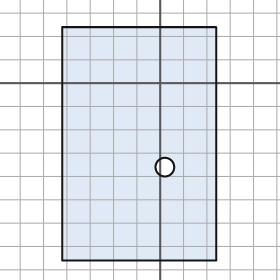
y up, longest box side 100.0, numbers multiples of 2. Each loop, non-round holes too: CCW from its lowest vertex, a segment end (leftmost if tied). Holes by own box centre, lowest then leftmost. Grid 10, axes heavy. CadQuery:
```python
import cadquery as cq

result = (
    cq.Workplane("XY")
    .moveTo(-42.0, -76.0)
    .lineTo(24.0, -76.0)
    .lineTo(24.0, 24.0)
    .lineTo(-42.0, 24.0)
    .close()
    .moveTo(2.0, -36.0)
    .circle(4.0)
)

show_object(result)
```